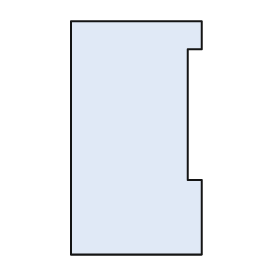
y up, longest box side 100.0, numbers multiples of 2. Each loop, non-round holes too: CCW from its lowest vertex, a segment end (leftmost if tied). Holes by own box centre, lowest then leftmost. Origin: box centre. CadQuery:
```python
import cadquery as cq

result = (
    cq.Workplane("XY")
    .moveTo(-28.0, -50.0)
    .lineTo(28.0, -50.0)
    .lineTo(28.0, -18.0)
    .lineTo(22.0, -18.0)
    .lineTo(22.0, 38.0)
    .lineTo(28.0, 38.0)
    .lineTo(28.0, 50.0)
    .lineTo(-28.0, 50.0)
    .close()
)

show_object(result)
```